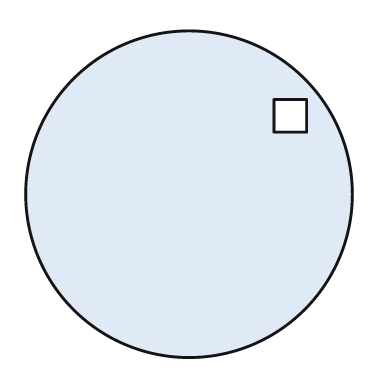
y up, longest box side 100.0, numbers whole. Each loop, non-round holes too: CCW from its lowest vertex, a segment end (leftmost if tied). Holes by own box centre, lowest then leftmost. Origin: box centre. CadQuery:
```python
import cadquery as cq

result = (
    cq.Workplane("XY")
    .moveTo(0.0, 0.0)
    .circle(50.0)
    .moveTo(26.0, 19.0)
    .lineTo(36.0, 19.0)
    .lineTo(36.0, 29.0)
    .lineTo(26.0, 29.0)
    .close()
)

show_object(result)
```